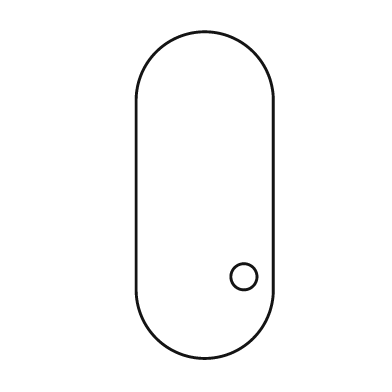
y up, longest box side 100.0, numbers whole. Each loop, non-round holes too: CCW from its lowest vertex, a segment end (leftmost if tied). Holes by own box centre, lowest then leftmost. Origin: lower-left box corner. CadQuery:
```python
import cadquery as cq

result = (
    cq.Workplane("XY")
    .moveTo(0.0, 21.0)
    .threePointArc((21.0, 0.0), (42.0, 21.0))
    .lineTo(42.0, 79.0)
    .threePointArc((21.0, 100.0), (0.0, 79.0))
    .close()
    .moveTo(33.0, 25.0)
    .circle(4.0)
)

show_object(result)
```